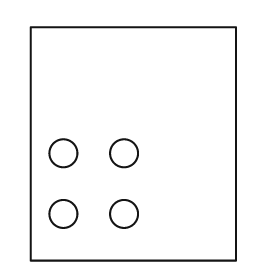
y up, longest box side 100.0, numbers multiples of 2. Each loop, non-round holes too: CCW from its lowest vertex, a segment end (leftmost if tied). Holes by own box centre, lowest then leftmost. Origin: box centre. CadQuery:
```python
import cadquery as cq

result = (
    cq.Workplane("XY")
    .moveTo(-44.0, -50.0)
    .lineTo(44.0, -50.0)
    .lineTo(44.0, 50.0)
    .lineTo(-44.0, 50.0)
    .close()
    .moveTo(-30.0, -30.0)
    .circle(6.0)
    .moveTo(-4.0, -30.0)
    .circle(6.0)
    .moveTo(-30.0, -4.0)
    .circle(6.0)
    .moveTo(-4.0, -4.0)
    .circle(6.0)
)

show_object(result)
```